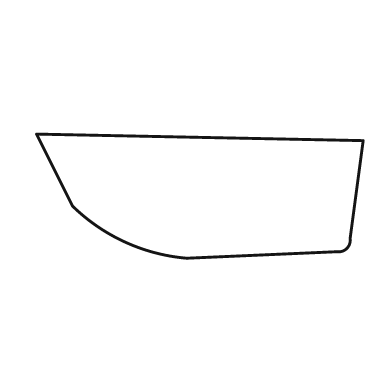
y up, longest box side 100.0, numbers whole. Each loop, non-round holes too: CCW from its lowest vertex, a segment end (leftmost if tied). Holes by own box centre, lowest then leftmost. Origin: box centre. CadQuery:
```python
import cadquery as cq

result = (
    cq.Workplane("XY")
    .moveTo(-4.0, -19.0)
    .lineTo(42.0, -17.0)
    .threePointArc((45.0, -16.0), (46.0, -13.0))
    .lineTo(50.0, 17.0)
    .lineTo(-50.0, 19.0)
    .lineTo(-39.0, -3.0)
    .threePointArc((-23.0, -14.0), (-4.0, -19.0))
    .close()
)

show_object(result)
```